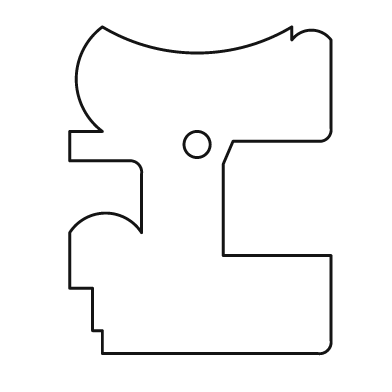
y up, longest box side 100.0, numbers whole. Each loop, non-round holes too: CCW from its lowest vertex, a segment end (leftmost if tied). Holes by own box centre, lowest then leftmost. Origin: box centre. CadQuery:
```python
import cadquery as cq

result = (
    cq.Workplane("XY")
    .moveTo(-30.0, -50.0)
    .lineTo(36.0, -50.0)
    .threePointArc((39.0, -49.0), (40.0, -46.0))
    .lineTo(40.0, -20.0)
    .lineTo(7.0, -20.0)
    .lineTo(7.0, 8.0)
    .lineTo(10.0, 15.0)
    .lineTo(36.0, 15.0)
    .threePointArc((39.0, 16.0), (40.0, 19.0))
    .lineTo(40.0, 46.0)
    .threePointArc((34.0, 49.0), (28.0, 46.0))
    .lineTo(28.0, 50.0)
    .threePointArc((-1.0, 42.0), (-30.0, 50.0))
    .threePointArc((-38.0, 34.0), (-30.0, 18.0))
    .lineTo(-40.0, 18.0)
    .lineTo(-40.0, 9.0)
    .lineTo(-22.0, 9.0)
    .threePointArc((-19.0, 8.0), (-18.0, 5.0))
    .lineTo(-18.0, -13.0)
    .threePointArc((-29.0, -7.0), (-40.0, -13.0))
    .lineTo(-40.0, -30.0)
    .lineTo(-33.0, -30.0)
    .lineTo(-33.0, -43.0)
    .lineTo(-30.0, -43.0)
    .close()
    .moveTo(-1.0, 14.0)
    .circle(4.0)
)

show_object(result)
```